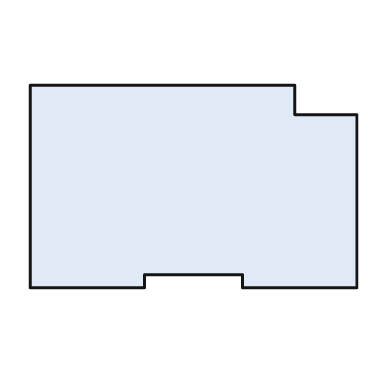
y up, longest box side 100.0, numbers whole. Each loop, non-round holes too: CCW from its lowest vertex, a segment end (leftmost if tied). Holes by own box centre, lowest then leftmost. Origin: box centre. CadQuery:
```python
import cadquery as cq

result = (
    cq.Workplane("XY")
    .moveTo(-50.0, -31.0)
    .lineTo(-15.0, -31.0)
    .lineTo(-15.0, -27.0)
    .lineTo(15.0, -27.0)
    .lineTo(15.0, -31.0)
    .lineTo(50.0, -31.0)
    .lineTo(50.0, 22.0)
    .lineTo(31.0, 22.0)
    .lineTo(31.0, 31.0)
    .lineTo(-50.0, 31.0)
    .close()
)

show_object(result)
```